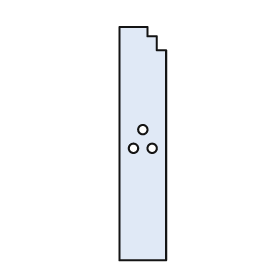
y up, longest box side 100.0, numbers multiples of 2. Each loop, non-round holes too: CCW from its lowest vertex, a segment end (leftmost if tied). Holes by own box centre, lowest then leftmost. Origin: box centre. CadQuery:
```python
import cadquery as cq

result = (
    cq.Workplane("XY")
    .moveTo(-10.0, -50.0)
    .lineTo(10.0, -50.0)
    .lineTo(10.0, 40.0)
    .lineTo(6.0, 40.0)
    .lineTo(6.0, 46.0)
    .lineTo(2.0, 46.0)
    .lineTo(2.0, 50.0)
    .lineTo(-10.0, 50.0)
    .close()
    .moveTo(-4.0, -2.0)
    .circle(2.0)
    .moveTo(4.0, -2.0)
    .circle(2.0)
    .moveTo(0.0, 6.0)
    .circle(2.0)
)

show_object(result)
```